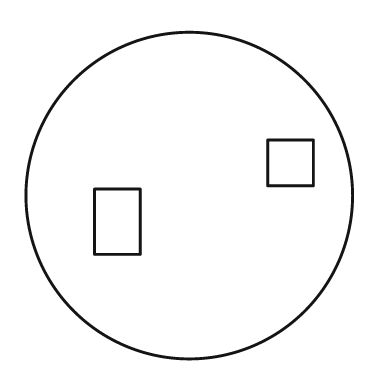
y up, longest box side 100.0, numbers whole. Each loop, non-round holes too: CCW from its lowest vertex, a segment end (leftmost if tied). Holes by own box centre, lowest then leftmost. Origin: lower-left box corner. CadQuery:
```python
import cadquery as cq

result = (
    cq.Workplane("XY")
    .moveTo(50.0, 50.0)
    .circle(50.0)
    .moveTo(21.0, 32.0)
    .lineTo(35.0, 32.0)
    .lineTo(35.0, 52.0)
    .lineTo(21.0, 52.0)
    .close()
    .moveTo(74.0, 53.0)
    .lineTo(88.0, 53.0)
    .lineTo(88.0, 67.0)
    .lineTo(74.0, 67.0)
    .close()
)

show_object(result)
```